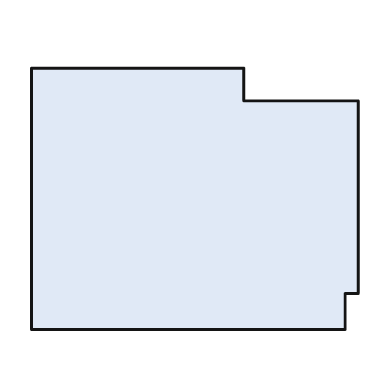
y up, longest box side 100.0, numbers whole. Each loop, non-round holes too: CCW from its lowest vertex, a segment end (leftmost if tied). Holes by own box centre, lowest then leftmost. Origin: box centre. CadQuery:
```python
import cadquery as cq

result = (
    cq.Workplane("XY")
    .moveTo(-50.0, -40.0)
    .lineTo(46.0, -40.0)
    .lineTo(46.0, -29.0)
    .lineTo(50.0, -29.0)
    .lineTo(50.0, 30.0)
    .lineTo(15.0, 30.0)
    .lineTo(15.0, 40.0)
    .lineTo(-50.0, 40.0)
    .close()
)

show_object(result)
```